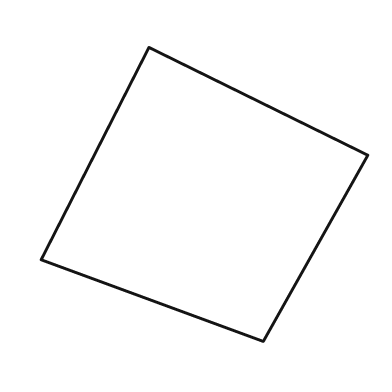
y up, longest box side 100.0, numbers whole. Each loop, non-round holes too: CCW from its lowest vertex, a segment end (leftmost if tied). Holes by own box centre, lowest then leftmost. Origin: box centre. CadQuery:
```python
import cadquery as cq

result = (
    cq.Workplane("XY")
    .moveTo(18.0, -45.0)
    .lineTo(50.0, 12.0)
    .lineTo(-17.0, 45.0)
    .lineTo(-50.0, -20.0)
    .close()
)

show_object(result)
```